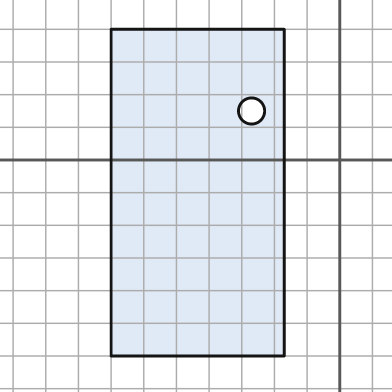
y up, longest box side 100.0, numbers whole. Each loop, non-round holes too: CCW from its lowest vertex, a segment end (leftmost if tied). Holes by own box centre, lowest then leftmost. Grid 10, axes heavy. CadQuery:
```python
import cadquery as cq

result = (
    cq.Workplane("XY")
    .moveTo(-70.0, -60.0)
    .lineTo(-17.0, -60.0)
    .lineTo(-17.0, 40.0)
    .lineTo(-70.0, 40.0)
    .close()
    .moveTo(-27.0, 15.0)
    .circle(4.0)
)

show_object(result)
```